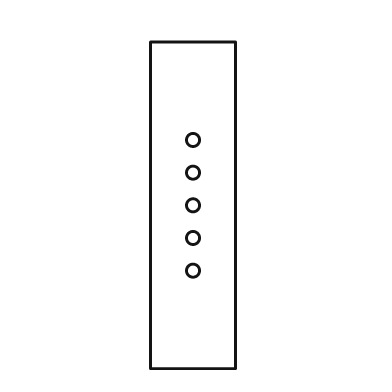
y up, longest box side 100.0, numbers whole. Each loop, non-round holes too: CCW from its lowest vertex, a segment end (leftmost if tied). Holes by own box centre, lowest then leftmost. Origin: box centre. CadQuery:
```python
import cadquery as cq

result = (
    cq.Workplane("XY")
    .moveTo(-13.0, -50.0)
    .lineTo(13.0, -50.0)
    .lineTo(13.0, 50.0)
    .lineTo(-13.0, 50.0)
    .close()
    .moveTo(0.0, -20.0)
    .circle(2.0)
    .moveTo(0.0, -10.0)
    .circle(2.0)
    .moveTo(0.0, 0.0)
    .circle(2.0)
    .moveTo(0.0, 10.0)
    .circle(2.0)
    .moveTo(0.0, 20.0)
    .circle(2.0)
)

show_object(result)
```